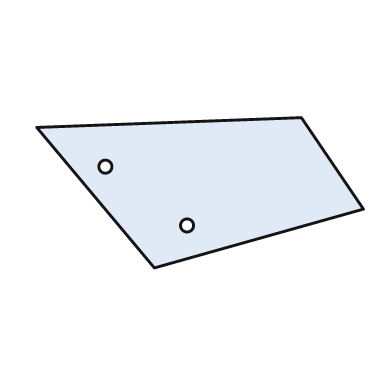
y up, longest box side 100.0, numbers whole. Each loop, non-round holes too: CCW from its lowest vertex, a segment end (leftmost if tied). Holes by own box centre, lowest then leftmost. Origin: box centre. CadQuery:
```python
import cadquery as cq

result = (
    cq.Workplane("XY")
    .moveTo(-14.0, -23.0)
    .lineTo(50.0, -5.0)
    .lineTo(31.0, 23.0)
    .lineTo(-50.0, 20.0)
    .close()
    .moveTo(-4.0, -10.0)
    .circle(2.0)
    .moveTo(-29.0, 8.0)
    .circle(2.0)
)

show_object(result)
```